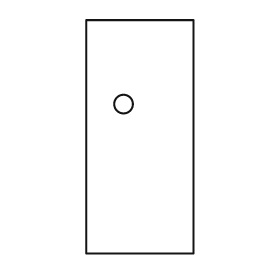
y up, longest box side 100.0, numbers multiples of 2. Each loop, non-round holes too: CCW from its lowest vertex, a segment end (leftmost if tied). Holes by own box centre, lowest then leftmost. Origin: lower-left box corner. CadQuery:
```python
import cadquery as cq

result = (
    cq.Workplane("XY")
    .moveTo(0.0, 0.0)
    .lineTo(46.0, 0.0)
    .lineTo(46.0, 100.0)
    .lineTo(0.0, 100.0)
    .close()
    .moveTo(16.0, 64.0)
    .circle(4.0)
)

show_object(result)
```